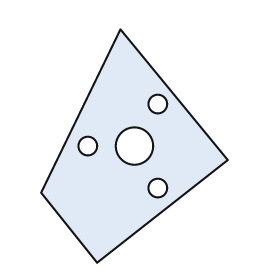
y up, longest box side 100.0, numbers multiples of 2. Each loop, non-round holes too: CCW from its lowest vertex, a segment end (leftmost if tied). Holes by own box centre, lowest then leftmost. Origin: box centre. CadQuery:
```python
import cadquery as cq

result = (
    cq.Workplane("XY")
    .moveTo(-16.0, -50.0)
    .lineTo(40.0, -6.0)
    .lineTo(-6.0, 50.0)
    .lineTo(-40.0, -20.0)
    .close()
    .moveTo(10.0, -18.0)
    .circle(4.0)
    .moveTo(-20.0, 0.0)
    .circle(4.0)
    .moveTo(0.0, 0.0)
    .circle(8.0)
    .moveTo(10.0, 18.0)
    .circle(4.0)
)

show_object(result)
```